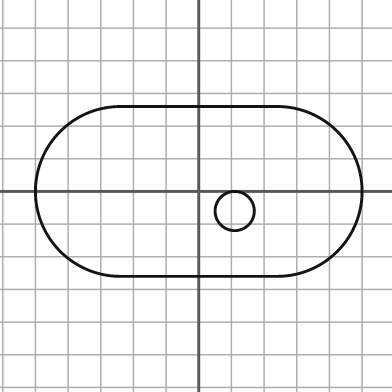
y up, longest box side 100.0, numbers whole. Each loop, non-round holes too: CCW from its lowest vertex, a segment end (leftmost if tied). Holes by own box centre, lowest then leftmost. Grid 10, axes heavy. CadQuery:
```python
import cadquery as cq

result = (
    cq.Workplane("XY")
    .moveTo(-24.0, -26.0)
    .lineTo(24.0, -26.0)
    .threePointArc((50.0, 0.0), (24.0, 26.0))
    .lineTo(-24.0, 26.0)
    .threePointArc((-50.0, 0.0), (-24.0, -26.0))
    .close()
    .moveTo(11.0, -6.0)
    .circle(6.0)
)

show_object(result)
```